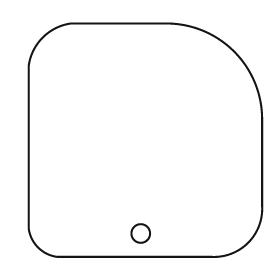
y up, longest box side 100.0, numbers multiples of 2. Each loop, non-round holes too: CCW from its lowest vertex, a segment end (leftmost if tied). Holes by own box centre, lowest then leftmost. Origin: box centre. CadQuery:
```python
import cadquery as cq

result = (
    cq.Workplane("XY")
    .moveTo(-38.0, -50.0)
    .lineTo(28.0, -50.0)
    .threePointArc((44.0, -44.0), (50.0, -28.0))
    .lineTo(50.0, 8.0)
    .threePointArc((38.0, 38.0), (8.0, 50.0))
    .lineTo(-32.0, 50.0)
    .threePointArc((-44.0, 44.0), (-50.0, 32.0))
    .lineTo(-50.0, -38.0)
    .threePointArc((-46.0, -46.0), (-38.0, -50.0))
    .close()
    .moveTo(-2.0, -40.0)
    .circle(4.0)
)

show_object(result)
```